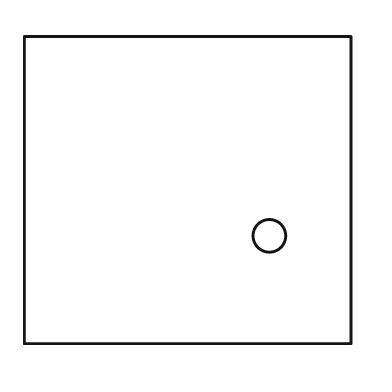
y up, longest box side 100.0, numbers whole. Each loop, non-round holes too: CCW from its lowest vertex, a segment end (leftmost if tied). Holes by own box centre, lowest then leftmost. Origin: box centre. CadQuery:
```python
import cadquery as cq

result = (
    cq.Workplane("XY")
    .moveTo(-50.0, -47.0)
    .lineTo(50.0, -47.0)
    .lineTo(50.0, 47.0)
    .lineTo(-50.0, 47.0)
    .close()
    .moveTo(25.0, -14.0)
    .circle(5.0)
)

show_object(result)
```